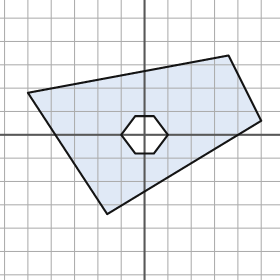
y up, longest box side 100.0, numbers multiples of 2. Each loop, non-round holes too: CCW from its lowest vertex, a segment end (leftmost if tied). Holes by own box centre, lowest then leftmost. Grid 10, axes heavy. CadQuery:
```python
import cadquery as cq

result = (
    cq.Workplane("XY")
    .moveTo(-16.0, -34.0)
    .lineTo(50.0, 6.0)
    .lineTo(36.0, 34.0)
    .lineTo(-50.0, 18.0)
    .close()
    .moveTo(-4.0, -8.0)
    .lineTo(4.0, -8.0)
    .lineTo(10.0, 0.0)
    .lineTo(4.0, 8.0)
    .lineTo(-4.0, 8.0)
    .lineTo(-10.0, 0.0)
    .close()
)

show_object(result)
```